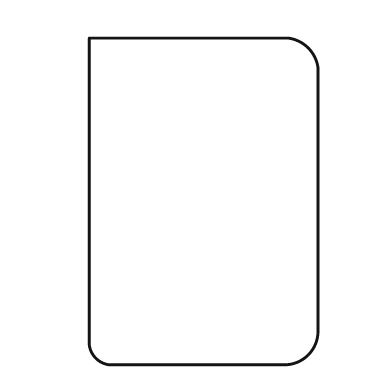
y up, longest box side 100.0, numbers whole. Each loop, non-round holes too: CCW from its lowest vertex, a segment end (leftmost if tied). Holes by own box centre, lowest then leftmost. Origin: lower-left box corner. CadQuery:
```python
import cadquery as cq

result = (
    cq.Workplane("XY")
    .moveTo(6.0, 0.0)
    .lineTo(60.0, 0.0)
    .threePointArc((67.0, 3.0), (70.0, 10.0))
    .lineTo(70.0, 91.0)
    .threePointArc((67.0, 97.0), (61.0, 100.0))
    .lineTo(0.0, 100.0)
    .lineTo(0.0, 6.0)
    .threePointArc((2.0, 2.0), (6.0, 0.0))
    .close()
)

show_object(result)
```